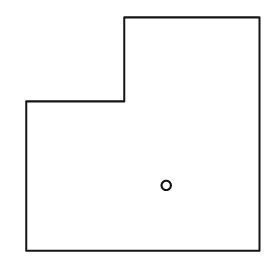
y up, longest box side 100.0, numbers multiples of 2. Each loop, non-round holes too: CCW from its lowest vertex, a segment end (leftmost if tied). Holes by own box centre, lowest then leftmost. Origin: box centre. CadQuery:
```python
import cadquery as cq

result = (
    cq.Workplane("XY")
    .moveTo(-50.0, -50.0)
    .lineTo(50.0, -50.0)
    .lineTo(50.0, 50.0)
    .lineTo(-8.0, 50.0)
    .lineTo(-8.0, 14.0)
    .lineTo(-50.0, 14.0)
    .close()
    .moveTo(10.0, -22.0)
    .circle(2.0)
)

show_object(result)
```